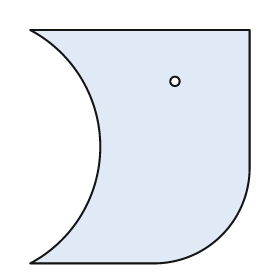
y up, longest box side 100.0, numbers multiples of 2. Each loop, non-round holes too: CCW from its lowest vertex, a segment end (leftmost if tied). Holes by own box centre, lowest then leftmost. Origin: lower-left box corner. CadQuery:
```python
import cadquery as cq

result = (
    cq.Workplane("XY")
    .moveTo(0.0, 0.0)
    .lineTo(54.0, 0.0)
    .threePointArc((82.0, 12.0), (94.0, 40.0))
    .lineTo(94.0, 100.0)
    .lineTo(0.0, 100.0)
    .threePointArc((30.0, 50.0), (0.0, 0.0))
    .close()
    .moveTo(62.0, 78.0)
    .circle(2.0)
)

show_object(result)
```